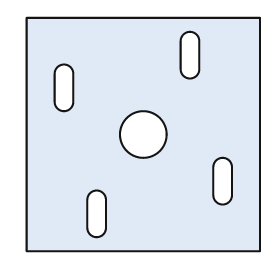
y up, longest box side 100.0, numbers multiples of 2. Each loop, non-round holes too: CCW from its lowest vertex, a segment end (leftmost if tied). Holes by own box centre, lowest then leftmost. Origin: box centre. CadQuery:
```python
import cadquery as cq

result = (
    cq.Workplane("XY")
    .moveTo(-50.0, -50.0)
    .lineTo(50.0, -50.0)
    .lineTo(50.0, 50.0)
    .lineTo(-50.0, 50.0)
    .close()
    .moveTo(-24.0, -40.0)
    .threePointArc((-20.0, -44.0), (-16.0, -40.0))
    .lineTo(-16.0, -28.0)
    .threePointArc((-20.0, -24.0), (-24.0, -28.0))
    .close()
    .moveTo(30.0, -26.0)
    .threePointArc((34.0, -30.0), (38.0, -26.0))
    .lineTo(38.0, -14.0)
    .threePointArc((34.0, -10.0), (30.0, -14.0))
    .close()
    .moveTo(0.0, 0.0)
    .circle(10.0)
    .moveTo(-38.0, 14.0)
    .threePointArc((-34.0, 10.0), (-30.0, 14.0))
    .lineTo(-30.0, 26.0)
    .threePointArc((-34.0, 30.0), (-38.0, 26.0))
    .close()
    .moveTo(16.0, 28.0)
    .threePointArc((20.0, 24.0), (24.0, 28.0))
    .lineTo(24.0, 40.0)
    .threePointArc((20.0, 44.0), (16.0, 40.0))
    .close()
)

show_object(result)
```